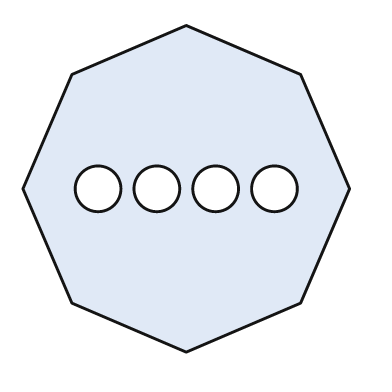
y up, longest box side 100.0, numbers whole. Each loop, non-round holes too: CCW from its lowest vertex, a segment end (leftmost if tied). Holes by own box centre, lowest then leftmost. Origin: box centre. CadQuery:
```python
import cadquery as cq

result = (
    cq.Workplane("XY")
    .moveTo(0.0, -50.0)
    .lineTo(35.0, -35.0)
    .lineTo(50.0, 0.0)
    .lineTo(35.0, 35.0)
    .lineTo(0.0, 50.0)
    .lineTo(-35.0, 35.0)
    .lineTo(-50.0, 0.0)
    .lineTo(-35.0, -35.0)
    .close()
    .moveTo(-27.0, 0.0)
    .circle(7.0)
    .moveTo(-9.0, 0.0)
    .circle(7.0)
    .moveTo(9.0, 0.0)
    .circle(7.0)
    .moveTo(27.0, 0.0)
    .circle(7.0)
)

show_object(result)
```